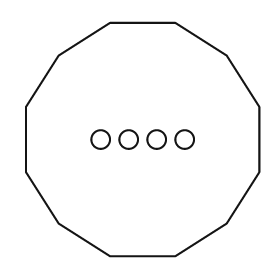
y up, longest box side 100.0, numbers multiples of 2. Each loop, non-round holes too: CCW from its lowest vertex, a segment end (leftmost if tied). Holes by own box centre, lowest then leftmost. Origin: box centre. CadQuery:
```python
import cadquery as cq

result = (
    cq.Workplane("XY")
    .moveTo(-14.0, -50.0)
    .lineTo(14.0, -50.0)
    .lineTo(36.0, -36.0)
    .lineTo(50.0, -14.0)
    .lineTo(50.0, 14.0)
    .lineTo(36.0, 36.0)
    .lineTo(14.0, 50.0)
    .lineTo(-14.0, 50.0)
    .lineTo(-36.0, 36.0)
    .lineTo(-50.0, 14.0)
    .lineTo(-50.0, -14.0)
    .lineTo(-36.0, -36.0)
    .close()
    .moveTo(-18.0, 0.0)
    .circle(4.0)
    .moveTo(-6.0, 0.0)
    .circle(4.0)
    .moveTo(6.0, 0.0)
    .circle(4.0)
    .moveTo(18.0, 0.0)
    .circle(4.0)
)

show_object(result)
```